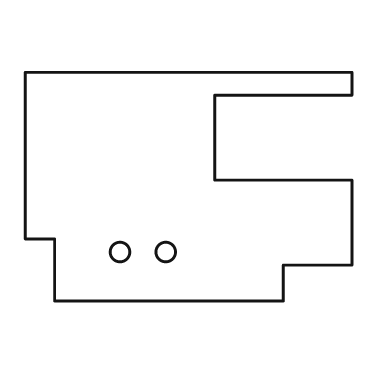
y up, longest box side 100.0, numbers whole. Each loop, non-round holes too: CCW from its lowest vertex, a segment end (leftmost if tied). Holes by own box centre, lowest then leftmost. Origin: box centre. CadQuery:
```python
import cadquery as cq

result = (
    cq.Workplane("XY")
    .moveTo(-41.0, -35.0)
    .lineTo(29.0, -35.0)
    .lineTo(29.0, -24.0)
    .lineTo(50.0, -24.0)
    .lineTo(50.0, 2.0)
    .lineTo(8.0, 2.0)
    .lineTo(8.0, 28.0)
    .lineTo(50.0, 28.0)
    .lineTo(50.0, 35.0)
    .lineTo(-50.0, 35.0)
    .lineTo(-50.0, -16.0)
    .lineTo(-41.0, -16.0)
    .close()
    .moveTo(-21.0, -20.0)
    .circle(3.0)
    .moveTo(-7.0, -20.0)
    .circle(3.0)
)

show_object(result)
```